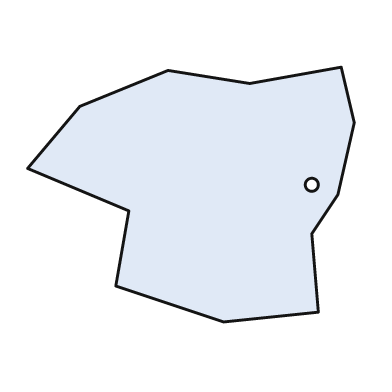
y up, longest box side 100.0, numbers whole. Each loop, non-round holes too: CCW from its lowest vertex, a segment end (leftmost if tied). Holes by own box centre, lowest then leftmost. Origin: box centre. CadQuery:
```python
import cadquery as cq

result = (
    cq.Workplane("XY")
    .moveTo(10.0, -39.0)
    .lineTo(39.0, -36.0)
    .lineTo(37.0, -12.0)
    .lineTo(45.0, 0.0)
    .lineTo(50.0, 22.0)
    .lineTo(46.0, 39.0)
    .lineTo(18.0, 34.0)
    .lineTo(-7.0, 38.0)
    .lineTo(-34.0, 27.0)
    .lineTo(-50.0, 8.0)
    .lineTo(-19.0, -5.0)
    .lineTo(-23.0, -28.0)
    .close()
    .moveTo(37.0, 3.0)
    .circle(2.0)
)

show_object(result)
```